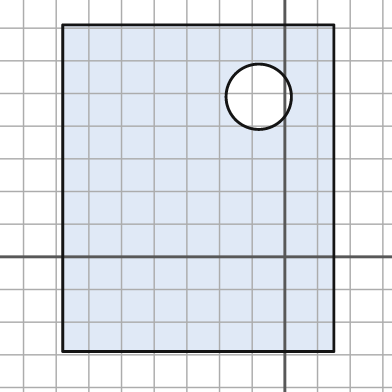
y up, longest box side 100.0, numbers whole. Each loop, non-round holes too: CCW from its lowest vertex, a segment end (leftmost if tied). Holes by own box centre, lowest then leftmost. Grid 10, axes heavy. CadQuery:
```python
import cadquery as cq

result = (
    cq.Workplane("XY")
    .moveTo(-68.0, -29.0)
    .lineTo(15.0, -29.0)
    .lineTo(15.0, 71.0)
    .lineTo(-68.0, 71.0)
    .close()
    .moveTo(-8.0, 49.0)
    .circle(10.0)
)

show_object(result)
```